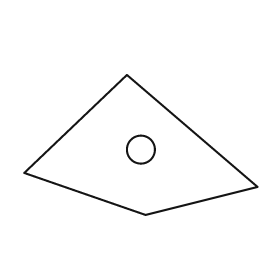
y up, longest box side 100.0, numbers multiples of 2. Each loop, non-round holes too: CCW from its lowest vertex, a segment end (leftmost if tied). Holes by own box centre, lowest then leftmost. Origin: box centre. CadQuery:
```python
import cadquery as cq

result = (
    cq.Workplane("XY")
    .moveTo(2.0, -30.0)
    .lineTo(50.0, -18.0)
    .lineTo(-6.0, 30.0)
    .lineTo(-50.0, -12.0)
    .close()
    .moveTo(0.0, -2.0)
    .circle(6.0)
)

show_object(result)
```